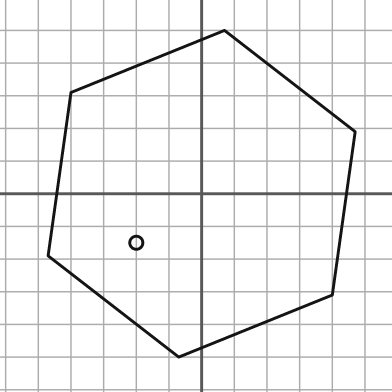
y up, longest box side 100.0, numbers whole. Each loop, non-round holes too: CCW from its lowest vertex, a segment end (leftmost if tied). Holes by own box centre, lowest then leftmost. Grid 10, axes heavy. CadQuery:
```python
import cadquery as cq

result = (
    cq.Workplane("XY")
    .moveTo(-7.0, -50.0)
    .lineTo(40.0, -31.0)
    .lineTo(47.0, 19.0)
    .lineTo(7.0, 50.0)
    .lineTo(-40.0, 31.0)
    .lineTo(-47.0, -19.0)
    .close()
    .moveTo(-20.0, -15.0)
    .circle(2.0)
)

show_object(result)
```